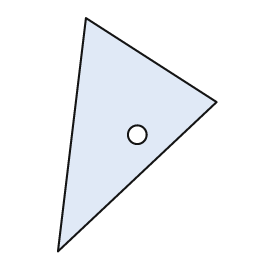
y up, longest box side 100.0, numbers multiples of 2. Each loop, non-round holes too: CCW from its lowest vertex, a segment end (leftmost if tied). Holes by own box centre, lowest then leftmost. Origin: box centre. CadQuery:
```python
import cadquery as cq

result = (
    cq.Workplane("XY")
    .moveTo(-34.0, -50.0)
    .lineTo(34.0, 14.0)
    .lineTo(-22.0, 50.0)
    .close()
    .moveTo(0.0, 0.0)
    .circle(4.0)
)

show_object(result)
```